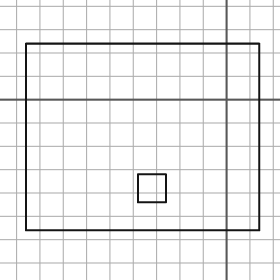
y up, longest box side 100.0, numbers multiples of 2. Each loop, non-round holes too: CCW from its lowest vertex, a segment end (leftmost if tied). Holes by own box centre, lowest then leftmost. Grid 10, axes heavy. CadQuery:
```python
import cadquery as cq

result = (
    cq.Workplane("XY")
    .moveTo(-86.0, -56.0)
    .lineTo(14.0, -56.0)
    .lineTo(14.0, 24.0)
    .lineTo(-86.0, 24.0)
    .close()
    .moveTo(-38.0, -44.0)
    .lineTo(-26.0, -44.0)
    .lineTo(-26.0, -32.0)
    .lineTo(-38.0, -32.0)
    .close()
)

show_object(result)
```